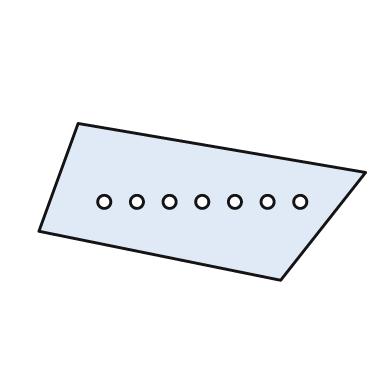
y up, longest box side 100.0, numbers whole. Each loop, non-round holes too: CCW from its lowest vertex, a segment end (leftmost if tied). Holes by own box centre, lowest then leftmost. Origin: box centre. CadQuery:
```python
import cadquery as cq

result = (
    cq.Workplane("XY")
    .moveTo(24.0, -24.0)
    .lineTo(50.0, 9.0)
    .lineTo(-38.0, 24.0)
    .lineTo(-50.0, -9.0)
    .close()
    .moveTo(-30.0, 0.0)
    .circle(2.0)
    .moveTo(-20.0, 0.0)
    .circle(2.0)
    .moveTo(-10.0, 0.0)
    .circle(2.0)
    .moveTo(0.0, 0.0)
    .circle(2.0)
    .moveTo(10.0, 0.0)
    .circle(2.0)
    .moveTo(20.0, 0.0)
    .circle(2.0)
    .moveTo(30.0, 0.0)
    .circle(2.0)
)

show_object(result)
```